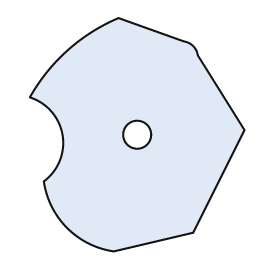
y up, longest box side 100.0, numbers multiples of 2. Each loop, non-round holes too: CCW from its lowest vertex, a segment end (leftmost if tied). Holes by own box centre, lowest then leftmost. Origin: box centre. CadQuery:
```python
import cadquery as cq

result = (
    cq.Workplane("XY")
    .moveTo(-10.0, -50.0)
    .lineTo(24.0, -42.0)
    .lineTo(46.0, 2.0)
    .lineTo(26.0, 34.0)
    .threePointArc((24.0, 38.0), (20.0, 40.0))
    .lineTo(-8.0, 50.0)
    .threePointArc((-30.0, 36.0), (-46.0, 16.0))
    .threePointArc((-32.0, 0.0), (-40.0, -20.0))
    .threePointArc((-30.0, -40.0), (-10.0, -50.0))
    .close()
    .moveTo(0.0, 0.0)
    .circle(6.0)
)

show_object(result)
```